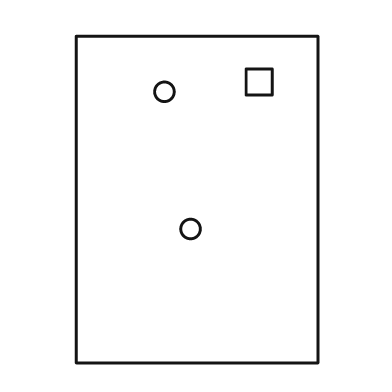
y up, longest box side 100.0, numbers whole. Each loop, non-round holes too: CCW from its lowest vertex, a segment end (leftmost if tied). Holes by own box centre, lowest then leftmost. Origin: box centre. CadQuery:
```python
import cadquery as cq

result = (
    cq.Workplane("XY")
    .moveTo(-37.0, -50.0)
    .lineTo(37.0, -50.0)
    .lineTo(37.0, 50.0)
    .lineTo(-37.0, 50.0)
    .close()
    .moveTo(-2.0, -9.0)
    .circle(3.0)
    .moveTo(-10.0, 33.0)
    .circle(3.0)
    .moveTo(15.0, 32.0)
    .lineTo(23.0, 32.0)
    .lineTo(23.0, 40.0)
    .lineTo(15.0, 40.0)
    .close()
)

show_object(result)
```